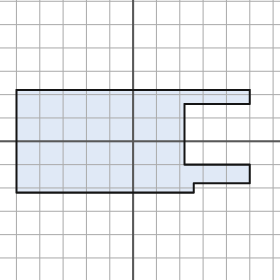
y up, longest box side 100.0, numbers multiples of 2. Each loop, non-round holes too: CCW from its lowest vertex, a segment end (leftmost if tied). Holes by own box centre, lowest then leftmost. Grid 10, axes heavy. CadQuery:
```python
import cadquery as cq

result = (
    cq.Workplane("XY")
    .moveTo(-50.0, -22.0)
    .lineTo(26.0, -22.0)
    .lineTo(26.0, -18.0)
    .lineTo(50.0, -18.0)
    .lineTo(50.0, -10.0)
    .lineTo(22.0, -10.0)
    .lineTo(22.0, 16.0)
    .lineTo(50.0, 16.0)
    .lineTo(50.0, 22.0)
    .lineTo(-50.0, 22.0)
    .close()
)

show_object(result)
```